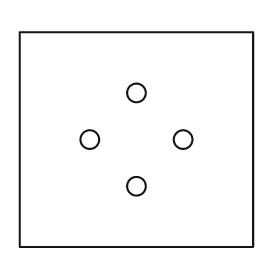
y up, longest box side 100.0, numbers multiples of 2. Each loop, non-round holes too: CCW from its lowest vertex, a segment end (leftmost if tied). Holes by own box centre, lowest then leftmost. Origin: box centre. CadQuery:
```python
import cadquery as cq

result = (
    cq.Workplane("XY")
    .moveTo(-50.0, -46.0)
    .lineTo(50.0, -46.0)
    .lineTo(50.0, 46.0)
    .lineTo(-50.0, 46.0)
    .close()
    .moveTo(0.0, -20.0)
    .circle(4.0)
    .moveTo(-20.0, 0.0)
    .circle(4.0)
    .moveTo(20.0, 0.0)
    .circle(4.0)
    .moveTo(0.0, 20.0)
    .circle(4.0)
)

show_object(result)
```